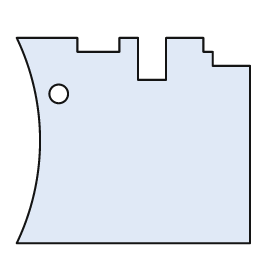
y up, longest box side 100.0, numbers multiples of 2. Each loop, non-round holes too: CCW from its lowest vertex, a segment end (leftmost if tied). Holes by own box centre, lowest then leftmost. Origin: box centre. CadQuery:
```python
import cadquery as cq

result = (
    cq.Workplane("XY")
    .moveTo(-50.0, -44.0)
    .lineTo(50.0, -44.0)
    .lineTo(50.0, 32.0)
    .lineTo(34.0, 32.0)
    .lineTo(34.0, 38.0)
    .lineTo(30.0, 38.0)
    .lineTo(30.0, 44.0)
    .lineTo(14.0, 44.0)
    .lineTo(14.0, 26.0)
    .lineTo(2.0, 26.0)
    .lineTo(2.0, 44.0)
    .lineTo(-6.0, 44.0)
    .lineTo(-6.0, 38.0)
    .lineTo(-24.0, 38.0)
    .lineTo(-24.0, 44.0)
    .lineTo(-50.0, 44.0)
    .threePointArc((-40.0, 0.0), (-50.0, -44.0))
    .close()
    .moveTo(-32.0, 20.0)
    .circle(4.0)
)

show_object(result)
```